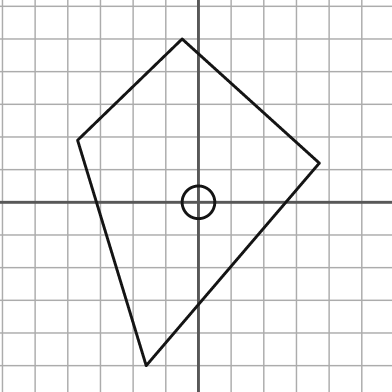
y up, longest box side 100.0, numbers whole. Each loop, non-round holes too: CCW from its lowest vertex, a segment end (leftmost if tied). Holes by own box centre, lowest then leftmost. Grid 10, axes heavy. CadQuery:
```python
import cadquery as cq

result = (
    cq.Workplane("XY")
    .moveTo(-16.0, -50.0)
    .lineTo(37.0, 12.0)
    .lineTo(-5.0, 50.0)
    .lineTo(-37.0, 19.0)
    .close()
    .moveTo(0.0, 0.0)
    .circle(5.0)
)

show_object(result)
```